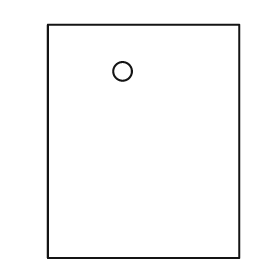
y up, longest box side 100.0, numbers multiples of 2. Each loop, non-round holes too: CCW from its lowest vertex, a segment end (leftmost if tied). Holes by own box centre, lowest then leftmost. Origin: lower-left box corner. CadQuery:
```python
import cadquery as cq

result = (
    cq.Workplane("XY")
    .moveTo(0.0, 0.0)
    .lineTo(82.0, 0.0)
    .lineTo(82.0, 100.0)
    .lineTo(0.0, 100.0)
    .close()
    .moveTo(32.0, 80.0)
    .circle(4.0)
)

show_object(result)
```